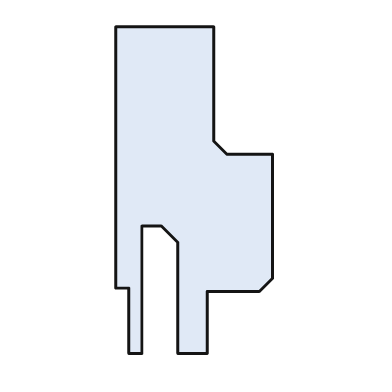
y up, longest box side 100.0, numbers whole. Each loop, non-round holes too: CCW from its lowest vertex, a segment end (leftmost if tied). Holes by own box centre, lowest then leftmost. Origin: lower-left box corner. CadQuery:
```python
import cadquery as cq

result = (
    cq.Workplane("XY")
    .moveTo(4.0, 0.0)
    .lineTo(8.0, 0.0)
    .lineTo(8.0, 39.0)
    .lineTo(14.0, 39.0)
    .lineTo(19.0, 34.0)
    .lineTo(19.0, 0.0)
    .lineTo(28.0, 0.0)
    .lineTo(28.0, 19.0)
    .lineTo(44.0, 19.0)
    .lineTo(48.0, 23.0)
    .lineTo(48.0, 61.0)
    .lineTo(34.0, 61.0)
    .lineTo(30.0, 65.0)
    .lineTo(30.0, 100.0)
    .lineTo(0.0, 100.0)
    .lineTo(0.0, 20.0)
    .lineTo(4.0, 20.0)
    .close()
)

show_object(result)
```